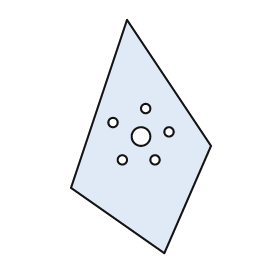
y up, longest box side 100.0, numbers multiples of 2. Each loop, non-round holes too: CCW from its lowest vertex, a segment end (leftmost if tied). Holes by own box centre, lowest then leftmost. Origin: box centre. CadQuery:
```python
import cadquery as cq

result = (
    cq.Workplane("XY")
    .moveTo(10.0, -50.0)
    .lineTo(30.0, -4.0)
    .lineTo(-6.0, 50.0)
    .lineTo(-30.0, -22.0)
    .close()
    .moveTo(-8.0, -10.0)
    .circle(2.0)
    .moveTo(6.0, -10.0)
    .circle(2.0)
    .moveTo(0.0, 0.0)
    .circle(4.0)
    .moveTo(12.0, 2.0)
    .circle(2.0)
    .moveTo(-12.0, 6.0)
    .circle(2.0)
    .moveTo(2.0, 12.0)
    .circle(2.0)
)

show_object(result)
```